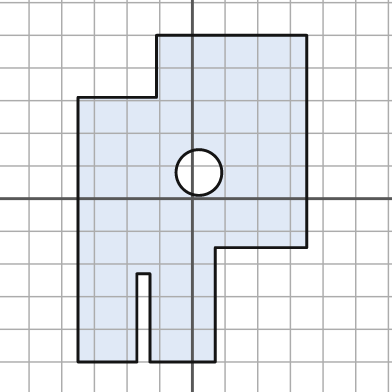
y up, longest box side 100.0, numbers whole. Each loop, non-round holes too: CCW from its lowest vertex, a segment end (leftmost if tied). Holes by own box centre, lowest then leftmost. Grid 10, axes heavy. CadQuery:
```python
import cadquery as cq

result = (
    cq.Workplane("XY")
    .moveTo(-35.0, -50.0)
    .lineTo(-17.0, -50.0)
    .lineTo(-17.0, -23.0)
    .lineTo(-13.0, -23.0)
    .lineTo(-13.0, -50.0)
    .lineTo(7.0, -50.0)
    .lineTo(7.0, -15.0)
    .lineTo(35.0, -15.0)
    .lineTo(35.0, 50.0)
    .lineTo(-11.0, 50.0)
    .lineTo(-11.0, 31.0)
    .lineTo(-35.0, 31.0)
    .close()
    .moveTo(2.0, 8.0)
    .circle(7.0)
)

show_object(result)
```